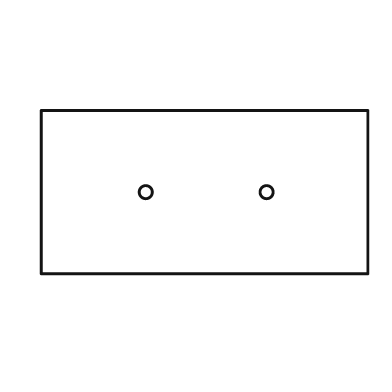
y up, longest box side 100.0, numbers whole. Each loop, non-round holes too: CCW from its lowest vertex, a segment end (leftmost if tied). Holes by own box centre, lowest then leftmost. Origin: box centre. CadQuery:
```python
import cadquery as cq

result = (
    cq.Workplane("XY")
    .moveTo(-50.0, -25.0)
    .lineTo(50.0, -25.0)
    .lineTo(50.0, 25.0)
    .lineTo(-50.0, 25.0)
    .close()
    .moveTo(-18.0, 0.0)
    .circle(2.0)
    .moveTo(19.0, 0.0)
    .circle(2.0)
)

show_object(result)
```